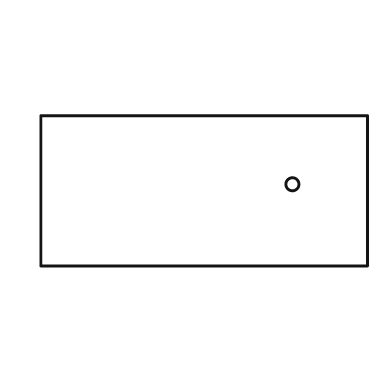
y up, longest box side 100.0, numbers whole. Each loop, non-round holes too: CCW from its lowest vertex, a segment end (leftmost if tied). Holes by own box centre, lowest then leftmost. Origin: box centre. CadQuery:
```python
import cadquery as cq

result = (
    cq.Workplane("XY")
    .moveTo(-50.0, -23.0)
    .lineTo(50.0, -23.0)
    .lineTo(50.0, 23.0)
    .lineTo(-50.0, 23.0)
    .close()
    .moveTo(27.0, 2.0)
    .circle(2.0)
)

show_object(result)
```